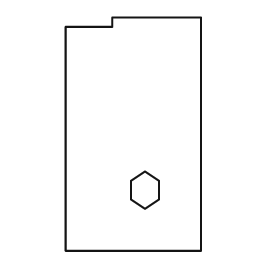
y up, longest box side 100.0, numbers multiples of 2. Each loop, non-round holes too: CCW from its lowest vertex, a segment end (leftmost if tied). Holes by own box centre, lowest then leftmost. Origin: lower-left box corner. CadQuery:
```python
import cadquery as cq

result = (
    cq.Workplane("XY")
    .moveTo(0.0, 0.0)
    .lineTo(58.0, 0.0)
    .lineTo(58.0, 100.0)
    .lineTo(20.0, 100.0)
    .lineTo(20.0, 96.0)
    .lineTo(0.0, 96.0)
    .close()
    .moveTo(34.0, 18.0)
    .lineTo(40.0, 22.0)
    .lineTo(40.0, 30.0)
    .lineTo(34.0, 34.0)
    .lineTo(28.0, 30.0)
    .lineTo(28.0, 22.0)
    .close()
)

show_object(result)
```